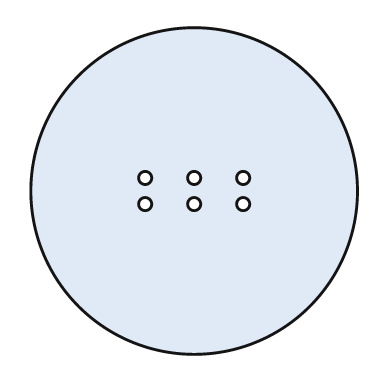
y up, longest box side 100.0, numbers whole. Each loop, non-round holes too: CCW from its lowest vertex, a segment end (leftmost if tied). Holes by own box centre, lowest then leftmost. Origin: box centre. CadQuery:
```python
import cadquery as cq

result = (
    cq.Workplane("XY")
    .moveTo(0.0, 0.0)
    .circle(50.0)
    .moveTo(-15.0, -4.0)
    .circle(2.0)
    .moveTo(0.0, -4.0)
    .circle(2.0)
    .moveTo(15.0, -4.0)
    .circle(2.0)
    .moveTo(-15.0, 4.0)
    .circle(2.0)
    .moveTo(0.0, 4.0)
    .circle(2.0)
    .moveTo(15.0, 4.0)
    .circle(2.0)
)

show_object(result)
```